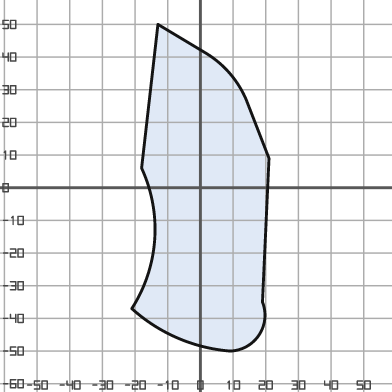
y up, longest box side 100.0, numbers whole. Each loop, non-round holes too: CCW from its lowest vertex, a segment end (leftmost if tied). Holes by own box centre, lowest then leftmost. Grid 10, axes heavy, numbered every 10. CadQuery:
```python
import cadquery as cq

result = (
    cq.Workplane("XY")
    .moveTo(9.0, -50.0)
    .threePointArc((18.0, -45.0), (19.0, -35.0))
    .lineTo(21.0, 9.0)
    .lineTo(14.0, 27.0)
    .threePointArc((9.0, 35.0), (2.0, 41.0))
    .lineTo(-13.0, 50.0)
    .lineTo(-18.0, 6.0)
    .threePointArc((-14.0, -16.0), (-21.0, -37.0))
    .threePointArc((-7.0, -46.0), (9.0, -50.0))
    .close()
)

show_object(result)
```